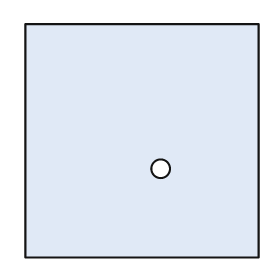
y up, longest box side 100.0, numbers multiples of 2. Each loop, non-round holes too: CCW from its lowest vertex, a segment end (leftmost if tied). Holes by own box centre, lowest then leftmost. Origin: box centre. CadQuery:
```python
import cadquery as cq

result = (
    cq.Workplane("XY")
    .moveTo(-50.0, -50.0)
    .lineTo(50.0, -50.0)
    .lineTo(50.0, 50.0)
    .lineTo(-50.0, 50.0)
    .close()
    .moveTo(8.0, -12.0)
    .circle(4.0)
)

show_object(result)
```